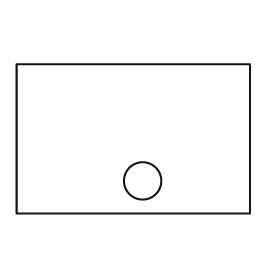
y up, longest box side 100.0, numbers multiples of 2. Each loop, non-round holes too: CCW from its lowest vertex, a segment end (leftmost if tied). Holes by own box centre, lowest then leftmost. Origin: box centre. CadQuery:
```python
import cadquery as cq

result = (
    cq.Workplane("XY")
    .moveTo(-50.0, -32.0)
    .lineTo(50.0, -32.0)
    .lineTo(50.0, 32.0)
    .lineTo(-50.0, 32.0)
    .close()
    .moveTo(4.0, -18.0)
    .circle(8.0)
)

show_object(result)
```